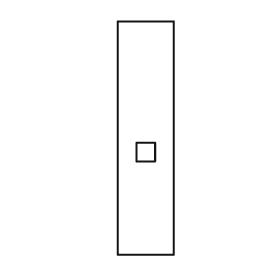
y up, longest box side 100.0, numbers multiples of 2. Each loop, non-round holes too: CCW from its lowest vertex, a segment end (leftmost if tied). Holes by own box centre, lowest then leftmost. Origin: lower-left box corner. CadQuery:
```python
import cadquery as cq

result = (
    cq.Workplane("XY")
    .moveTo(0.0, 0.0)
    .lineTo(24.0, 0.0)
    .lineTo(24.0, 100.0)
    .lineTo(0.0, 100.0)
    .close()
    .moveTo(8.0, 40.0)
    .lineTo(16.0, 40.0)
    .lineTo(16.0, 48.0)
    .lineTo(8.0, 48.0)
    .close()
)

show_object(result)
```